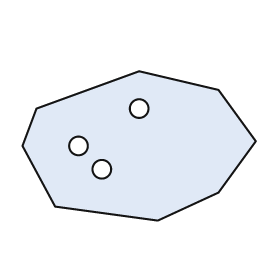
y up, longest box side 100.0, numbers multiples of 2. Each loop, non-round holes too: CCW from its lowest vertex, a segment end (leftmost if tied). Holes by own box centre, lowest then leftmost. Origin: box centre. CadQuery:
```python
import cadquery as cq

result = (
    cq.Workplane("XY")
    .moveTo(8.0, -32.0)
    .lineTo(34.0, -20.0)
    .lineTo(50.0, 2.0)
    .lineTo(34.0, 24.0)
    .lineTo(0.0, 32.0)
    .lineTo(-44.0, 16.0)
    .lineTo(-50.0, 0.0)
    .lineTo(-36.0, -26.0)
    .close()
    .moveTo(-16.0, -10.0)
    .circle(4.0)
    .moveTo(-26.0, 0.0)
    .circle(4.0)
    .moveTo(0.0, 16.0)
    .circle(4.0)
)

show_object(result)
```